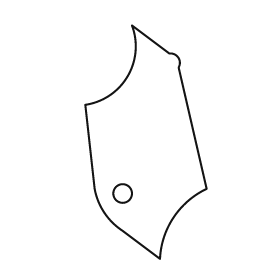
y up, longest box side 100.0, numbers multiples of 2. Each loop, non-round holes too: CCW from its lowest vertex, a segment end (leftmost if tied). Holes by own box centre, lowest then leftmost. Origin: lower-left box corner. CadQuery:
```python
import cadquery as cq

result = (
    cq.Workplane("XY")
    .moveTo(32.0, 0.0)
    .threePointArc((38.0, 18.0), (52.0, 30.0))
    .lineTo(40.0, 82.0)
    .threePointArc((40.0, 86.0), (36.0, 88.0))
    .lineTo(20.0, 100.0)
    .threePointArc((18.0, 78.0), (0.0, 66.0))
    .lineTo(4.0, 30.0)
    .threePointArc((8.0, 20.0), (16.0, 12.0))
    .close()
    .moveTo(16.0, 28.0)
    .circle(4.0)
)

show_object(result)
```